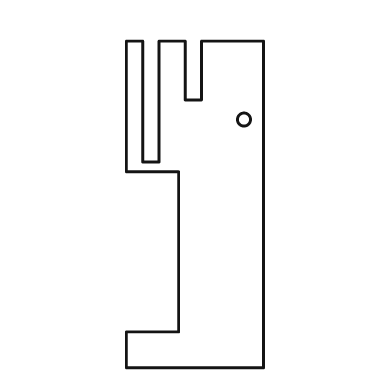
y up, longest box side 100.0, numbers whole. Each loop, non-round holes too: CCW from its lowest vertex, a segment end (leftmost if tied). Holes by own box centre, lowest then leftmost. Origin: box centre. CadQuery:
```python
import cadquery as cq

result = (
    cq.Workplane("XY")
    .moveTo(-21.0, -50.0)
    .lineTo(21.0, -50.0)
    .lineTo(21.0, 50.0)
    .lineTo(2.0, 50.0)
    .lineTo(2.0, 32.0)
    .lineTo(-3.0, 32.0)
    .lineTo(-3.0, 50.0)
    .lineTo(-11.0, 50.0)
    .lineTo(-11.0, 13.0)
    .lineTo(-16.0, 13.0)
    .lineTo(-16.0, 50.0)
    .lineTo(-21.0, 50.0)
    .lineTo(-21.0, 10.0)
    .lineTo(-5.0, 10.0)
    .lineTo(-5.0, -39.0)
    .lineTo(-21.0, -39.0)
    .close()
    .moveTo(15.0, 26.0)
    .circle(2.0)
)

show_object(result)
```